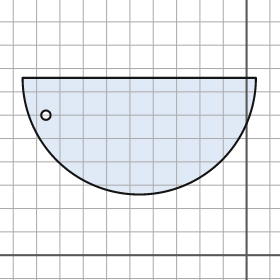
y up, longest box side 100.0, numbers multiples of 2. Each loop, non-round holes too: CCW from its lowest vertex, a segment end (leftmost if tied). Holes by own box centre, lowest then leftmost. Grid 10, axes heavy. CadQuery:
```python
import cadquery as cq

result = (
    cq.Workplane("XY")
    .moveTo(-96.0, 76.0)
    .threePointArc((-46.0, 26.0), (4.0, 76.0))
    .close()
    .moveTo(-86.0, 60.0)
    .circle(2.0)
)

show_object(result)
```